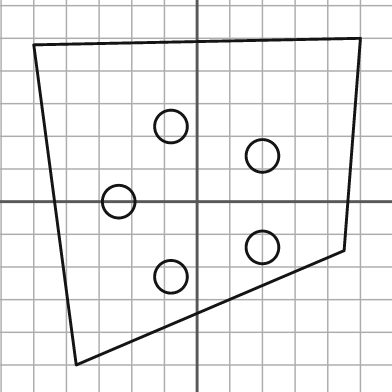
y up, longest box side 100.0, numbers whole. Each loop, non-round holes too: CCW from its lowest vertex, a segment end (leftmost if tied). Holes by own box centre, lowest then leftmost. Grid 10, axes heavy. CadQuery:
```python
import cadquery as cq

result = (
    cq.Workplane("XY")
    .moveTo(-37.0, -50.0)
    .lineTo(45.0, -15.0)
    .lineTo(50.0, 50.0)
    .lineTo(-50.0, 48.0)
    .close()
    .moveTo(-8.0, -23.0)
    .circle(5.0)
    .moveTo(20.0, -14.0)
    .circle(5.0)
    .moveTo(-24.0, 0.0)
    .circle(5.0)
    .moveTo(20.0, 14.0)
    .circle(5.0)
    .moveTo(-8.0, 23.0)
    .circle(5.0)
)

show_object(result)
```